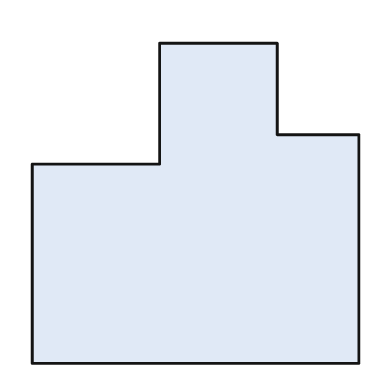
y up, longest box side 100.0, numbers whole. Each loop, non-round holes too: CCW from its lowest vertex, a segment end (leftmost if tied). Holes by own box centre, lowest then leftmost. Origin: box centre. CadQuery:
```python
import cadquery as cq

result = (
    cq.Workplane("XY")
    .moveTo(-50.0, -49.0)
    .lineTo(50.0, -49.0)
    .lineTo(50.0, 21.0)
    .lineTo(25.0, 21.0)
    .lineTo(25.0, 49.0)
    .lineTo(-11.0, 49.0)
    .lineTo(-11.0, 12.0)
    .lineTo(-50.0, 12.0)
    .close()
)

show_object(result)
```